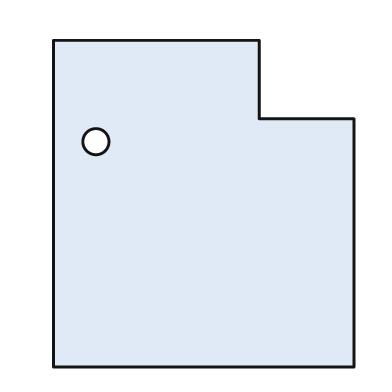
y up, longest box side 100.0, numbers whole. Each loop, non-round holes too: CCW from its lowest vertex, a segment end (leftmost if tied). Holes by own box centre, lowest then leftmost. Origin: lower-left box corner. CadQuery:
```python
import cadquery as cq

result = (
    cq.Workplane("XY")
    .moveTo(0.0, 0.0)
    .lineTo(92.0, 0.0)
    .lineTo(92.0, 76.0)
    .lineTo(63.0, 76.0)
    .lineTo(63.0, 100.0)
    .lineTo(0.0, 100.0)
    .close()
    .moveTo(13.0, 69.0)
    .circle(4.0)
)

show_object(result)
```